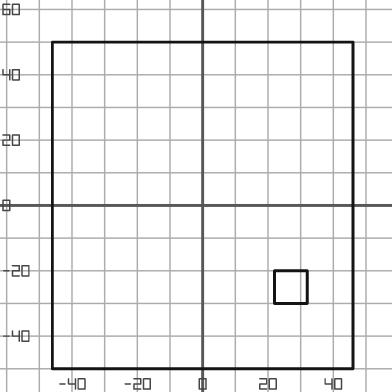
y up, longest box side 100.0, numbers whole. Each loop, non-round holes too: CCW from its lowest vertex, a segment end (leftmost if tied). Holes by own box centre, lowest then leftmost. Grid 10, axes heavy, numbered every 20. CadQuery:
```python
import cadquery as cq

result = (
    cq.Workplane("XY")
    .moveTo(-46.0, -50.0)
    .lineTo(46.0, -50.0)
    .lineTo(46.0, 50.0)
    .lineTo(-46.0, 50.0)
    .close()
    .moveTo(22.0, -30.0)
    .lineTo(32.0, -30.0)
    .lineTo(32.0, -20.0)
    .lineTo(22.0, -20.0)
    .close()
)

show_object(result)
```